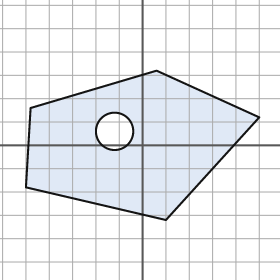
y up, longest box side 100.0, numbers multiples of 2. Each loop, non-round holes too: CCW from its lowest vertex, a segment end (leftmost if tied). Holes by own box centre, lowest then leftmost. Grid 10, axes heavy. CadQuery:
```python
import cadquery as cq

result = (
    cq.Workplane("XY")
    .moveTo(10.0, -32.0)
    .lineTo(50.0, 12.0)
    .lineTo(6.0, 32.0)
    .lineTo(-48.0, 16.0)
    .lineTo(-50.0, -18.0)
    .close()
    .moveTo(-12.0, 6.0)
    .circle(8.0)
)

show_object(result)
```